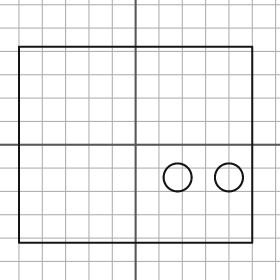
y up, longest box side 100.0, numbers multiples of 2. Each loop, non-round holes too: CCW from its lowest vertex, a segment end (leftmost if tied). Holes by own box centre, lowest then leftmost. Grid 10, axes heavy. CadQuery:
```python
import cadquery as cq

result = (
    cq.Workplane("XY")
    .moveTo(-50.0, -42.0)
    .lineTo(50.0, -42.0)
    .lineTo(50.0, 42.0)
    .lineTo(-50.0, 42.0)
    .close()
    .moveTo(18.0, -14.0)
    .circle(6.0)
    .moveTo(40.0, -14.0)
    .circle(6.0)
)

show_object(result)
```